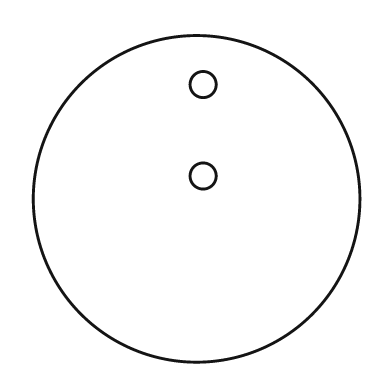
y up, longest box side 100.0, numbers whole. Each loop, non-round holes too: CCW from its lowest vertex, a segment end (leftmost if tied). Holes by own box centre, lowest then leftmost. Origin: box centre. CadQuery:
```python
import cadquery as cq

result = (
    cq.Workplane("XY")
    .moveTo(0.0, 0.0)
    .circle(50.0)
    .moveTo(2.0, 7.0)
    .circle(4.0)
    .moveTo(2.0, 35.0)
    .circle(4.0)
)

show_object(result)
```